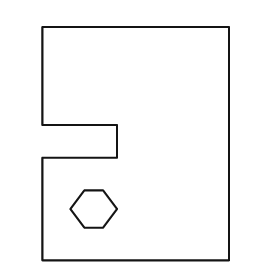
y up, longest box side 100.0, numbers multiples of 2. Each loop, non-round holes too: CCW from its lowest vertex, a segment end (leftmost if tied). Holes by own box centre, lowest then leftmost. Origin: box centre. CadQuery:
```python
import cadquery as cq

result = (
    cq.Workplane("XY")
    .moveTo(-40.0, -50.0)
    .lineTo(40.0, -50.0)
    .lineTo(40.0, 50.0)
    .lineTo(-40.0, 50.0)
    .lineTo(-40.0, 8.0)
    .lineTo(-8.0, 8.0)
    .lineTo(-8.0, -6.0)
    .lineTo(-40.0, -6.0)
    .close()
    .moveTo(-22.0, -36.0)
    .lineTo(-14.0, -36.0)
    .lineTo(-8.0, -28.0)
    .lineTo(-14.0, -20.0)
    .lineTo(-22.0, -20.0)
    .lineTo(-28.0, -28.0)
    .close()
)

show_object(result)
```